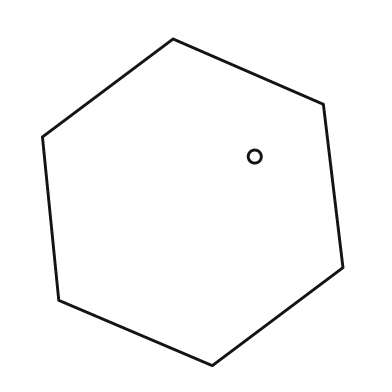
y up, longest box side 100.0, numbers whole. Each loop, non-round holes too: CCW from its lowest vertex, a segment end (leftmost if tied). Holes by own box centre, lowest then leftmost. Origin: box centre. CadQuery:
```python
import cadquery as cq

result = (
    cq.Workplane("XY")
    .moveTo(6.0, -50.0)
    .lineTo(46.0, -20.0)
    .lineTo(40.0, 30.0)
    .lineTo(-6.0, 50.0)
    .lineTo(-46.0, 20.0)
    .lineTo(-41.0, -30.0)
    .close()
    .moveTo(19.0, 14.0)
    .circle(2.0)
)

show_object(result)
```